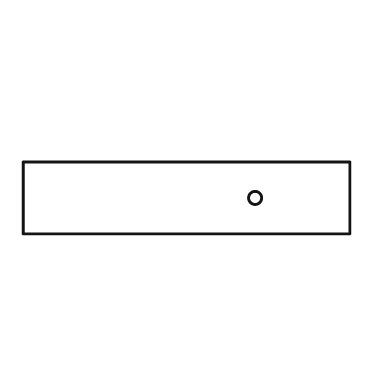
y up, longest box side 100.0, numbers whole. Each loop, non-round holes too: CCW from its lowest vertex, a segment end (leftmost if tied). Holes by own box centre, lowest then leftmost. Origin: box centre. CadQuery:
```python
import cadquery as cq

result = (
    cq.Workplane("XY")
    .moveTo(-50.0, -11.0)
    .lineTo(50.0, -11.0)
    .lineTo(50.0, 11.0)
    .lineTo(-50.0, 11.0)
    .close()
    .moveTo(21.0, 0.0)
    .circle(2.0)
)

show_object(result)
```